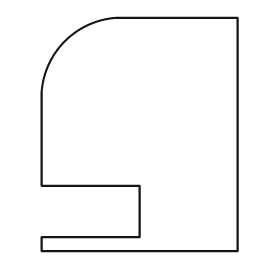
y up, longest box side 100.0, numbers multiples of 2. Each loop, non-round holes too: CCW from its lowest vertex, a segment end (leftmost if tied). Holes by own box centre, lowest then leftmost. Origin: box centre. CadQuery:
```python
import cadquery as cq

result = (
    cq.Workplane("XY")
    .moveTo(-42.0, -50.0)
    .lineTo(42.0, -50.0)
    .lineTo(42.0, 50.0)
    .lineTo(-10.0, 50.0)
    .threePointArc((-32.0, 40.0), (-42.0, 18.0))
    .lineTo(-42.0, -22.0)
    .lineTo(0.0, -22.0)
    .lineTo(0.0, -44.0)
    .lineTo(-42.0, -44.0)
    .close()
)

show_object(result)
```